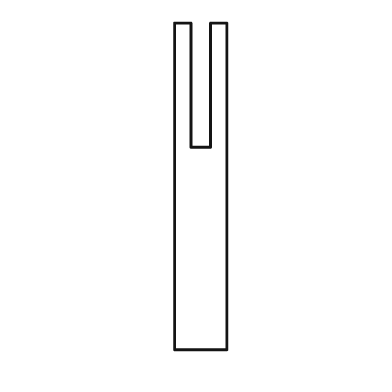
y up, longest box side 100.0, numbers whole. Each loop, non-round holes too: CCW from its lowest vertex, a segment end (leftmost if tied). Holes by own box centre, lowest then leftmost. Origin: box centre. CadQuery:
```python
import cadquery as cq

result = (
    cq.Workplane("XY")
    .moveTo(-8.0, -50.0)
    .lineTo(8.0, -50.0)
    .lineTo(8.0, 50.0)
    .lineTo(3.0, 50.0)
    .lineTo(3.0, 12.0)
    .lineTo(-3.0, 12.0)
    .lineTo(-3.0, 50.0)
    .lineTo(-8.0, 50.0)
    .close()
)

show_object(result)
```